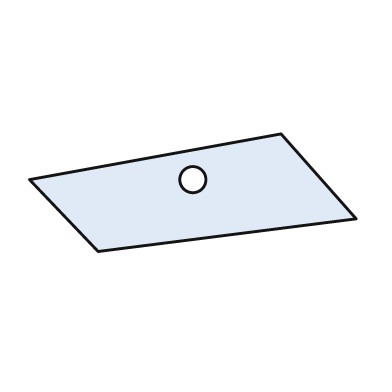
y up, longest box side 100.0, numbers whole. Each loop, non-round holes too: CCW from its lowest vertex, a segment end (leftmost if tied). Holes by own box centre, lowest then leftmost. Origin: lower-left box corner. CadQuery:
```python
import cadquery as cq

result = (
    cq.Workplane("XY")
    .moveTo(21.0, 0.0)
    .lineTo(100.0, 10.0)
    .lineTo(77.0, 36.0)
    .lineTo(0.0, 22.0)
    .close()
    .moveTo(50.0, 22.0)
    .circle(4.0)
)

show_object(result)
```